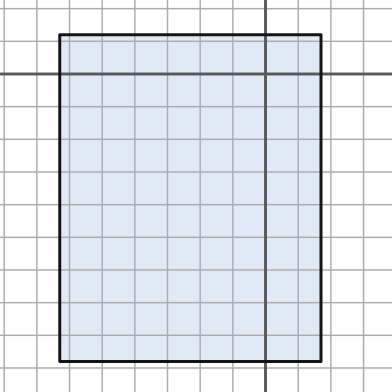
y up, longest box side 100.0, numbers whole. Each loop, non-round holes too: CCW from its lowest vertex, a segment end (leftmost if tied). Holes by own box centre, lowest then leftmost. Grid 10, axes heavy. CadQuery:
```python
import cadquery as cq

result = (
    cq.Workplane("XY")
    .moveTo(-63.0, -88.0)
    .lineTo(17.0, -88.0)
    .lineTo(17.0, 12.0)
    .lineTo(-63.0, 12.0)
    .close()
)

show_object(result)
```